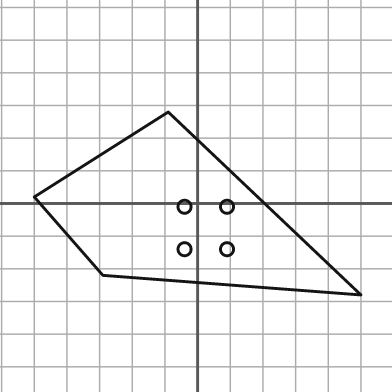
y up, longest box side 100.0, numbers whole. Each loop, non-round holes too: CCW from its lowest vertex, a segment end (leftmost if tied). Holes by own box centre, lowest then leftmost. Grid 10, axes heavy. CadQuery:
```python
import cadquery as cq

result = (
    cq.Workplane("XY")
    .moveTo(50.0, -28.0)
    .lineTo(-9.0, 28.0)
    .lineTo(-50.0, 2.0)
    .lineTo(-29.0, -22.0)
    .close()
    .moveTo(-4.0, -14.0)
    .circle(2.0)
    .moveTo(9.0, -14.0)
    .circle(2.0)
    .moveTo(-4.0, -1.0)
    .circle(2.0)
    .moveTo(9.0, -1.0)
    .circle(2.0)
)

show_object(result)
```